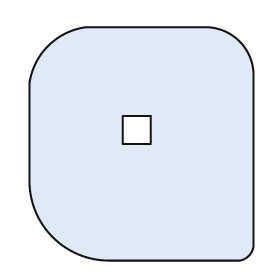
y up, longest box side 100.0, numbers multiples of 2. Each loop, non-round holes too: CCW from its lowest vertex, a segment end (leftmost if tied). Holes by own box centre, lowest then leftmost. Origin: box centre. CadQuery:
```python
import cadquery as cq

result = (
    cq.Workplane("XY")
    .moveTo(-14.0, -50.0)
    .lineTo(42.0, -50.0)
    .threePointArc((46.0, -48.0), (48.0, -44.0))
    .lineTo(48.0, 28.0)
    .threePointArc((42.0, 44.0), (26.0, 50.0))
    .lineTo(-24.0, 50.0)
    .threePointArc((-40.0, 42.0), (-48.0, 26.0))
    .lineTo(-48.0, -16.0)
    .threePointArc((-38.0, -40.0), (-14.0, -50.0))
    .close()
    .moveTo(-8.0, 0.0)
    .lineTo(4.0, 0.0)
    .lineTo(4.0, 12.0)
    .lineTo(-8.0, 12.0)
    .close()
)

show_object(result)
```